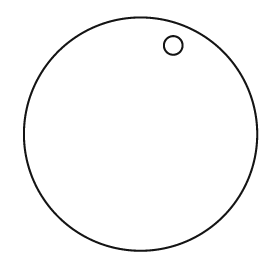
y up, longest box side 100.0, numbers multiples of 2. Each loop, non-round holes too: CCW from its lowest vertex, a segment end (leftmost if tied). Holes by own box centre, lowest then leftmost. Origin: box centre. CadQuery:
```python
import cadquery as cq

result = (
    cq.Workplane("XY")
    .moveTo(0.0, 0.0)
    .circle(50.0)
    .moveTo(14.0, 38.0)
    .circle(4.0)
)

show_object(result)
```